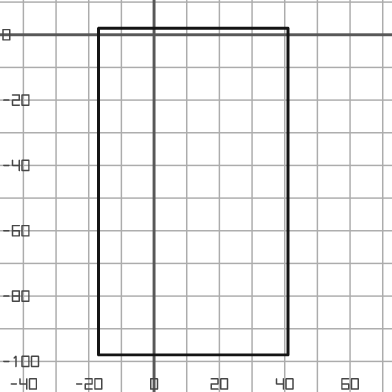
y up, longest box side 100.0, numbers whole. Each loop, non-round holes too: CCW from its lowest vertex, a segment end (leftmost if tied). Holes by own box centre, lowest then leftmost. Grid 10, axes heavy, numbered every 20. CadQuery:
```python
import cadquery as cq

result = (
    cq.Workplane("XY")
    .moveTo(-17.0, -98.0)
    .lineTo(41.0, -98.0)
    .lineTo(41.0, 2.0)
    .lineTo(-17.0, 2.0)
    .close()
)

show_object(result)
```